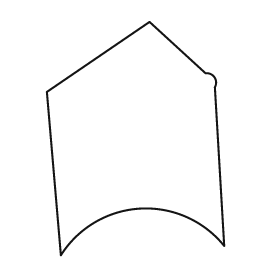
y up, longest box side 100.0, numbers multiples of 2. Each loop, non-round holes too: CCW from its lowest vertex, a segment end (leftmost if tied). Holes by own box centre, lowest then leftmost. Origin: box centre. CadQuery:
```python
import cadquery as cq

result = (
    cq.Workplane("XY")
    .moveTo(-32.0, -50.0)
    .threePointArc((2.0, -30.0), (38.0, -46.0))
    .lineTo(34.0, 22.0)
    .threePointArc((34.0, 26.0), (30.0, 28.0))
    .lineTo(6.0, 50.0)
    .lineTo(-38.0, 20.0)
    .close()
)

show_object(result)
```